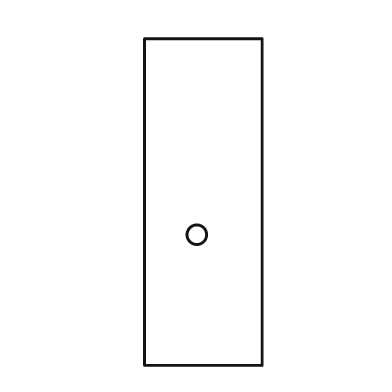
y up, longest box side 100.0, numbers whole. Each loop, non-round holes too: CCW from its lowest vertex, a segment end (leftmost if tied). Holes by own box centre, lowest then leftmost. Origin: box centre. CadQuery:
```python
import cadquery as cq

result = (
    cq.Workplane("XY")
    .moveTo(-18.0, -50.0)
    .lineTo(18.0, -50.0)
    .lineTo(18.0, 50.0)
    .lineTo(-18.0, 50.0)
    .close()
    .moveTo(-2.0, -10.0)
    .circle(3.0)
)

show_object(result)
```